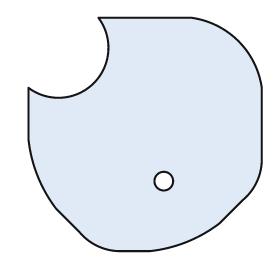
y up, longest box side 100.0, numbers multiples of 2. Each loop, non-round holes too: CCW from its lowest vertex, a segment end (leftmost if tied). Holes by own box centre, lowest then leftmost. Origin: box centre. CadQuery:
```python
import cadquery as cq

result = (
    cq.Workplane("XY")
    .moveTo(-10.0, -50.0)
    .lineTo(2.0, -50.0)
    .threePointArc((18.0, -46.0), (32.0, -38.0))
    .lineTo(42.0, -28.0)
    .threePointArc((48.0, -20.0), (50.0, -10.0))
    .lineTo(50.0, 20.0)
    .threePointArc((40.0, 40.0), (20.0, 50.0))
    .lineTo(-20.0, 50.0)
    .threePointArc((-22.0, 22.0), (-50.0, 20.0))
    .lineTo(-50.0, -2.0)
    .threePointArc((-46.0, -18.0), (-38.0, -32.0))
    .lineTo(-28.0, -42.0)
    .threePointArc((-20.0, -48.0), (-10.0, -50.0))
    .close()
    .moveTo(8.0, -20.0)
    .circle(4.0)
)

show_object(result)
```